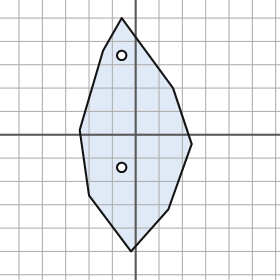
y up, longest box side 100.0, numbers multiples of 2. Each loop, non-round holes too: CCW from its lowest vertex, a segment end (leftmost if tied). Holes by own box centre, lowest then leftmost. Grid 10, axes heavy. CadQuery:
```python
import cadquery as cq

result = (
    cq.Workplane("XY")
    .moveTo(-2.0, -50.0)
    .lineTo(14.0, -32.0)
    .lineTo(24.0, -4.0)
    .lineTo(16.0, 20.0)
    .lineTo(-6.0, 50.0)
    .lineTo(-14.0, 36.0)
    .lineTo(-24.0, 2.0)
    .lineTo(-20.0, -26.0)
    .close()
    .moveTo(-6.0, -14.0)
    .circle(2.0)
    .moveTo(-6.0, 34.0)
    .circle(2.0)
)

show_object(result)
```